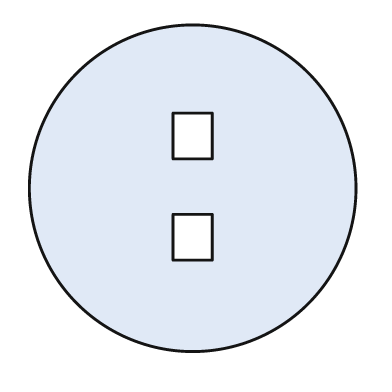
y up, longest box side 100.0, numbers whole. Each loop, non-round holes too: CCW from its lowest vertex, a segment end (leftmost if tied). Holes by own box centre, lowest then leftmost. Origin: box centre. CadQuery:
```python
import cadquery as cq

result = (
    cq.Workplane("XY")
    .moveTo(0.0, 0.0)
    .circle(50.0)
    .moveTo(-6.0, -22.0)
    .lineTo(6.0, -22.0)
    .lineTo(6.0, -8.0)
    .lineTo(-6.0, -8.0)
    .close()
    .moveTo(-6.0, 9.0)
    .lineTo(6.0, 9.0)
    .lineTo(6.0, 23.0)
    .lineTo(-6.0, 23.0)
    .close()
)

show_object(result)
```